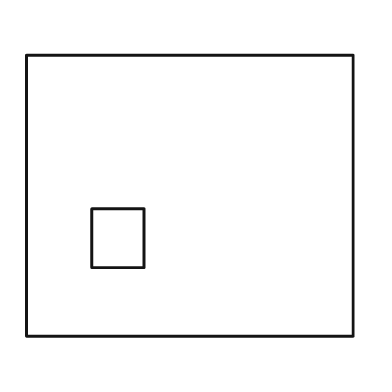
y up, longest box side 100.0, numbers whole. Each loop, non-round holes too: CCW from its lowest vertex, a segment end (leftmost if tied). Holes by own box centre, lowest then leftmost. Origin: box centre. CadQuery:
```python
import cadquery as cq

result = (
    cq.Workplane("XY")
    .moveTo(-50.0, -43.0)
    .lineTo(50.0, -43.0)
    .lineTo(50.0, 43.0)
    .lineTo(-50.0, 43.0)
    .close()
    .moveTo(-30.0, -22.0)
    .lineTo(-14.0, -22.0)
    .lineTo(-14.0, -4.0)
    .lineTo(-30.0, -4.0)
    .close()
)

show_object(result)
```